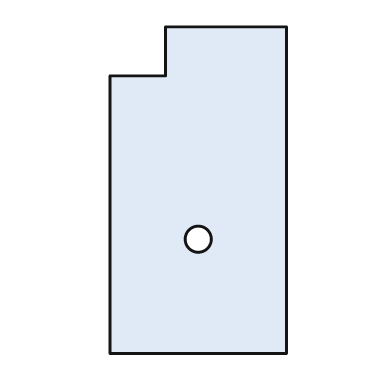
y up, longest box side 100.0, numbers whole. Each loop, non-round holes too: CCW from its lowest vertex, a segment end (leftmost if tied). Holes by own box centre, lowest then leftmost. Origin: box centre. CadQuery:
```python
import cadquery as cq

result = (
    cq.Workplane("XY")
    .moveTo(-27.0, -50.0)
    .lineTo(27.0, -50.0)
    .lineTo(27.0, 50.0)
    .lineTo(-10.0, 50.0)
    .lineTo(-10.0, 35.0)
    .lineTo(-27.0, 35.0)
    .close()
    .moveTo(0.0, -15.0)
    .circle(4.0)
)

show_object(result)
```